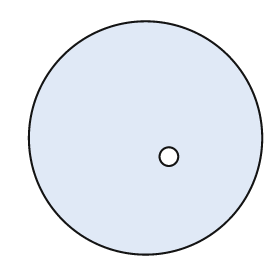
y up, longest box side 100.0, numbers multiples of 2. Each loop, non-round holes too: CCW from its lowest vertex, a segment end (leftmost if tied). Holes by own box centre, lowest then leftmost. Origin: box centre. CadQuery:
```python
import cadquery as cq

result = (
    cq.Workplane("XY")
    .moveTo(0.0, 0.0)
    .circle(50.0)
    .moveTo(10.0, -8.0)
    .circle(4.0)
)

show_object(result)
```